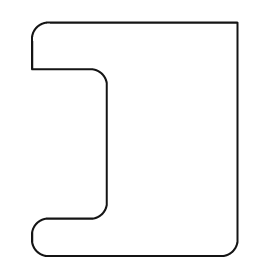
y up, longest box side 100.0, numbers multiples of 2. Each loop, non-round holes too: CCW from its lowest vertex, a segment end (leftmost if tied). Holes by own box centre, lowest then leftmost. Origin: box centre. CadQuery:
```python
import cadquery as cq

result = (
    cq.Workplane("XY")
    .moveTo(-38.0, -50.0)
    .lineTo(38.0, -50.0)
    .threePointArc((42.0, -48.0), (44.0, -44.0))
    .lineTo(44.0, 50.0)
    .lineTo(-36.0, 50.0)
    .threePointArc((-42.0, 48.0), (-44.0, 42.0))
    .lineTo(-44.0, 30.0)
    .lineTo(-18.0, 30.0)
    .threePointArc((-14.0, 28.0), (-12.0, 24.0))
    .lineTo(-12.0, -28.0)
    .threePointArc((-14.0, -32.0), (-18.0, -34.0))
    .lineTo(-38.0, -34.0)
    .threePointArc((-42.0, -36.0), (-44.0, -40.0))
    .lineTo(-44.0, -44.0)
    .threePointArc((-42.0, -48.0), (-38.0, -50.0))
    .close()
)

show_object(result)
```